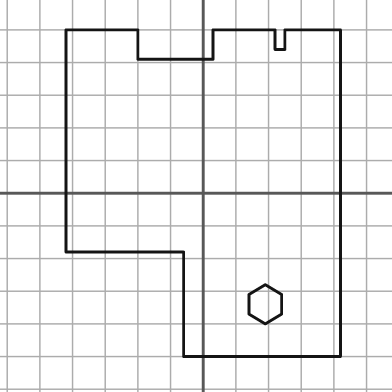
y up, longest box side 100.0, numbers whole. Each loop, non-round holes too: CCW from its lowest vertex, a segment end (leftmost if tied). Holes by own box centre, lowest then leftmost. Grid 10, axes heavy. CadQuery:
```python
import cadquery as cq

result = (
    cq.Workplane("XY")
    .moveTo(-6.0, -50.0)
    .lineTo(42.0, -50.0)
    .lineTo(42.0, 50.0)
    .lineTo(25.0, 50.0)
    .lineTo(25.0, 44.0)
    .lineTo(22.0, 44.0)
    .lineTo(22.0, 50.0)
    .lineTo(3.0, 50.0)
    .lineTo(3.0, 41.0)
    .lineTo(-20.0, 41.0)
    .lineTo(-20.0, 50.0)
    .lineTo(-42.0, 50.0)
    .lineTo(-42.0, -18.0)
    .lineTo(-6.0, -18.0)
    .close()
    .moveTo(19.0, -40.0)
    .lineTo(24.0, -37.0)
    .lineTo(24.0, -31.0)
    .lineTo(19.0, -28.0)
    .lineTo(14.0, -31.0)
    .lineTo(14.0, -37.0)
    .close()
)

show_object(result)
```